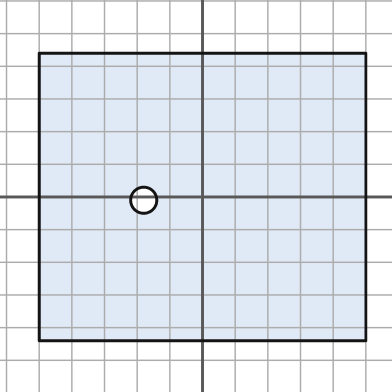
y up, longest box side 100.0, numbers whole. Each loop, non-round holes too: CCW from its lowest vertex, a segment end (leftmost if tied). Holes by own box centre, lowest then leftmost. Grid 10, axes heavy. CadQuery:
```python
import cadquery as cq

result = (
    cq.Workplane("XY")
    .moveTo(-50.0, -44.0)
    .lineTo(50.0, -44.0)
    .lineTo(50.0, 44.0)
    .lineTo(-50.0, 44.0)
    .close()
    .moveTo(-18.0, -1.0)
    .circle(4.0)
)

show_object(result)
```